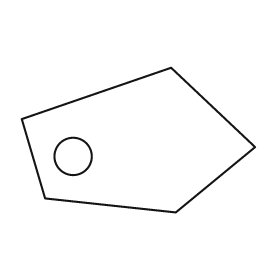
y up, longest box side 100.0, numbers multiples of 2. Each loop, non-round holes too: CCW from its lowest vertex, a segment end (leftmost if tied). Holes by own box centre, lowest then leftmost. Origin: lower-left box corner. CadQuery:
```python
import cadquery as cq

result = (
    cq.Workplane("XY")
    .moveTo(66.0, 0.0)
    .lineTo(100.0, 28.0)
    .lineTo(64.0, 62.0)
    .lineTo(0.0, 40.0)
    .lineTo(10.0, 6.0)
    .close()
    .moveTo(22.0, 24.0)
    .circle(8.0)
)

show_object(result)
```